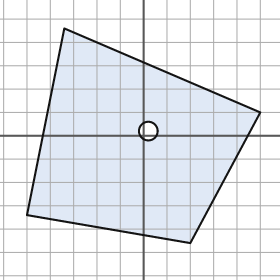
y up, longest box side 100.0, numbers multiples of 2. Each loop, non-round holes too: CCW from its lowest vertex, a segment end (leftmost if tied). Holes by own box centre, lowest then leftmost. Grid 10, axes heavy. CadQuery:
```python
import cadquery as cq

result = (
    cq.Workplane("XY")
    .moveTo(20.0, -46.0)
    .lineTo(50.0, 10.0)
    .lineTo(-34.0, 46.0)
    .lineTo(-50.0, -34.0)
    .close()
    .moveTo(2.0, 2.0)
    .circle(4.0)
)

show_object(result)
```